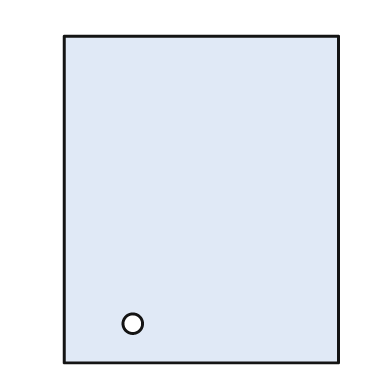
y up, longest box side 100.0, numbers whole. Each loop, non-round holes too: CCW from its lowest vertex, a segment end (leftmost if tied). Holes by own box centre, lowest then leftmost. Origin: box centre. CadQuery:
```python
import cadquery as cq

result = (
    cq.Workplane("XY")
    .moveTo(-42.0, -50.0)
    .lineTo(42.0, -50.0)
    .lineTo(42.0, 50.0)
    .lineTo(-42.0, 50.0)
    .close()
    .moveTo(-21.0, -38.0)
    .circle(3.0)
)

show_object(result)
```